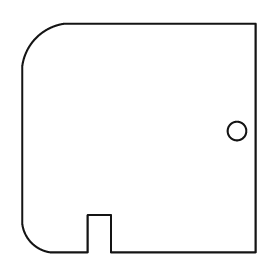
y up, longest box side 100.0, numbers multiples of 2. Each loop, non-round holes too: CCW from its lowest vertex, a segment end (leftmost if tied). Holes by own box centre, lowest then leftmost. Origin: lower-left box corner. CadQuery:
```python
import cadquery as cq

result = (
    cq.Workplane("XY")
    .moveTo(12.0, 0.0)
    .lineTo(28.0, 0.0)
    .lineTo(28.0, 16.0)
    .lineTo(38.0, 16.0)
    .lineTo(38.0, 0.0)
    .lineTo(100.0, 0.0)
    .lineTo(100.0, 98.0)
    .lineTo(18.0, 98.0)
    .threePointArc((6.0, 92.0), (0.0, 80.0))
    .lineTo(0.0, 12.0)
    .threePointArc((4.0, 4.0), (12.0, 0.0))
    .close()
    .moveTo(92.0, 52.0)
    .circle(4.0)
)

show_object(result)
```